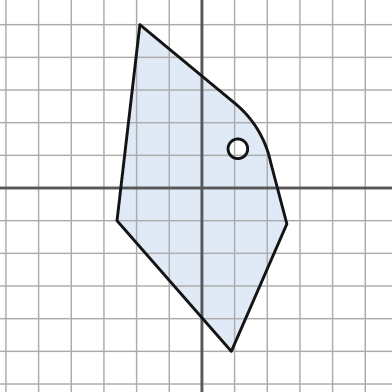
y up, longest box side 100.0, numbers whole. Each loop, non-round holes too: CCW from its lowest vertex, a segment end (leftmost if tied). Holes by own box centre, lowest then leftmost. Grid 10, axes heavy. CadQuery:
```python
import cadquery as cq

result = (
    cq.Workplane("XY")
    .moveTo(9.0, -50.0)
    .lineTo(26.0, -11.0)
    .lineTo(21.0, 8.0)
    .threePointArc((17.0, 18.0), (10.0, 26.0))
    .lineTo(-19.0, 50.0)
    .lineTo(-26.0, -10.0)
    .close()
    .moveTo(11.0, 12.0)
    .circle(3.0)
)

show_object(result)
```